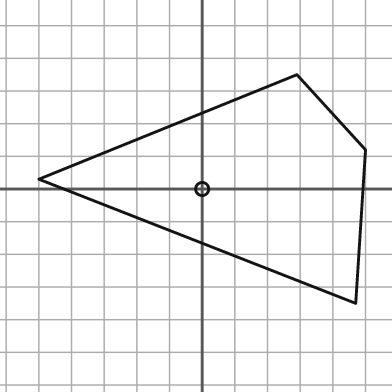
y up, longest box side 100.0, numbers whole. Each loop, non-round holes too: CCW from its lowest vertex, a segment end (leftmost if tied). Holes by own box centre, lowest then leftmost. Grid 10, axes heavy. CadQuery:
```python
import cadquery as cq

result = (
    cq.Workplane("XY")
    .moveTo(47.0, -35.0)
    .lineTo(50.0, 12.0)
    .lineTo(29.0, 35.0)
    .lineTo(-50.0, 3.0)
    .close()
    .moveTo(0.0, 0.0)
    .circle(2.0)
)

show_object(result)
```